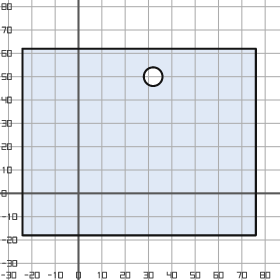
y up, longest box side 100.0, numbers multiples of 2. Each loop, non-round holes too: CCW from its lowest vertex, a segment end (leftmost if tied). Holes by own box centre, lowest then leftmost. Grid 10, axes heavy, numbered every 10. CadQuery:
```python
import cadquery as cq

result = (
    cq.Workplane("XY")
    .moveTo(-24.0, -18.0)
    .lineTo(76.0, -18.0)
    .lineTo(76.0, 62.0)
    .lineTo(-24.0, 62.0)
    .close()
    .moveTo(32.0, 50.0)
    .circle(4.0)
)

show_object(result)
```